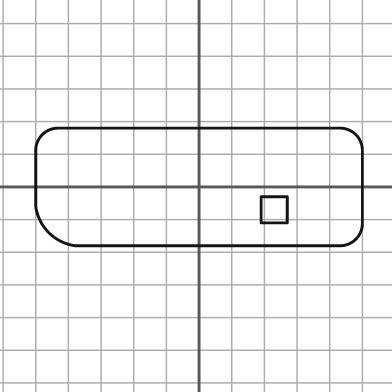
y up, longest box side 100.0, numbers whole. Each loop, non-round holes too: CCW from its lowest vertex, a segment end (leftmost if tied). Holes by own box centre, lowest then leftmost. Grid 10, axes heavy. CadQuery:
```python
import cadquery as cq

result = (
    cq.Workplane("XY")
    .moveTo(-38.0, -18.0)
    .lineTo(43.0, -18.0)
    .threePointArc((48.0, -16.0), (50.0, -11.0))
    .lineTo(50.0, 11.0)
    .threePointArc((48.0, 16.0), (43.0, 18.0))
    .lineTo(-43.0, 18.0)
    .threePointArc((-48.0, 16.0), (-50.0, 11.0))
    .lineTo(-50.0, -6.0)
    .threePointArc((-46.0, -14.0), (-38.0, -18.0))
    .close()
    .moveTo(19.0, -11.0)
    .lineTo(27.0, -11.0)
    .lineTo(27.0, -3.0)
    .lineTo(19.0, -3.0)
    .close()
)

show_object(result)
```